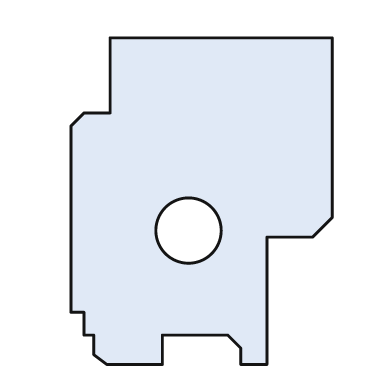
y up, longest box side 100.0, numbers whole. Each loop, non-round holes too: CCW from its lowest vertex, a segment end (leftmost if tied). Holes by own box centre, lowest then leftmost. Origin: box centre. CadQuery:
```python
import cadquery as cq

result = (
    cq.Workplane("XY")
    .moveTo(-29.0, -50.0)
    .lineTo(-12.0, -50.0)
    .lineTo(-12.0, -41.0)
    .lineTo(8.0, -41.0)
    .lineTo(12.0, -45.0)
    .lineTo(12.0, -50.0)
    .lineTo(20.0, -50.0)
    .lineTo(20.0, -11.0)
    .lineTo(34.0, -11.0)
    .lineTo(40.0, -5.0)
    .lineTo(40.0, 50.0)
    .lineTo(-28.0, 50.0)
    .lineTo(-28.0, 27.0)
    .lineTo(-36.0, 27.0)
    .lineTo(-40.0, 23.0)
    .lineTo(-40.0, -34.0)
    .lineTo(-36.0, -34.0)
    .lineTo(-36.0, -41.0)
    .lineTo(-33.0, -41.0)
    .lineTo(-33.0, -47.0)
    .close()
    .moveTo(-4.0, -9.0)
    .circle(10.0)
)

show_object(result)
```